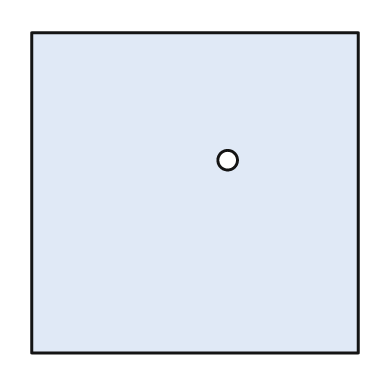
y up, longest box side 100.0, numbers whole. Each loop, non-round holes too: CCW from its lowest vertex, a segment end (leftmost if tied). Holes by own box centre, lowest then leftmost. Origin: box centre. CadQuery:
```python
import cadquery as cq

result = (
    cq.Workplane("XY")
    .moveTo(-50.0, -49.0)
    .lineTo(50.0, -49.0)
    .lineTo(50.0, 49.0)
    .lineTo(-50.0, 49.0)
    .close()
    .moveTo(10.0, 10.0)
    .circle(3.0)
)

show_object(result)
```